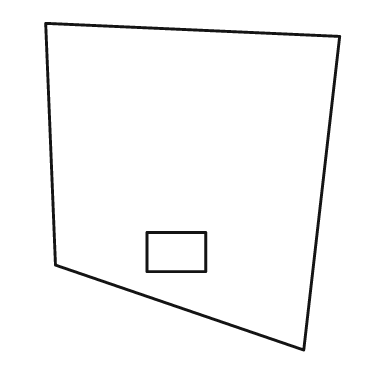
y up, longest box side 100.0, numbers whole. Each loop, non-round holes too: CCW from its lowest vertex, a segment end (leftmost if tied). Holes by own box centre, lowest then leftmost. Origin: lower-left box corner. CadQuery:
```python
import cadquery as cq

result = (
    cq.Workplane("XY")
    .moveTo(79.0, 0.0)
    .lineTo(90.0, 96.0)
    .lineTo(0.0, 100.0)
    .lineTo(3.0, 26.0)
    .close()
    .moveTo(31.0, 24.0)
    .lineTo(49.0, 24.0)
    .lineTo(49.0, 36.0)
    .lineTo(31.0, 36.0)
    .close()
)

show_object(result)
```